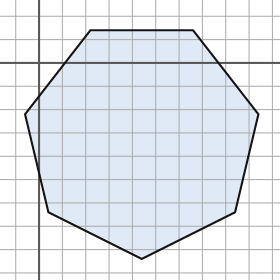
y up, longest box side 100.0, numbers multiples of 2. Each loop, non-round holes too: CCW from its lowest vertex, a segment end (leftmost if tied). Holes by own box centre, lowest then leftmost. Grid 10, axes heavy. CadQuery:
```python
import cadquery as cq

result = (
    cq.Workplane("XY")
    .moveTo(44.0, -84.0)
    .lineTo(84.0, -64.0)
    .lineTo(94.0, -22.0)
    .lineTo(66.0, 14.0)
    .lineTo(22.0, 14.0)
    .lineTo(-6.0, -22.0)
    .lineTo(4.0, -64.0)
    .close()
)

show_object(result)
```